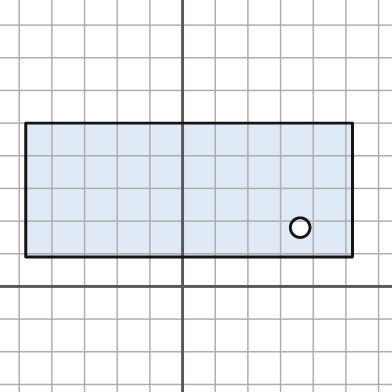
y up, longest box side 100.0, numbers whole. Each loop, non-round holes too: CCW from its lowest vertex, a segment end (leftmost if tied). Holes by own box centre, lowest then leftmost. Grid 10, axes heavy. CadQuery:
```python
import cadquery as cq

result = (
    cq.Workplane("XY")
    .moveTo(-48.0, 9.0)
    .lineTo(52.0, 9.0)
    .lineTo(52.0, 50.0)
    .lineTo(-48.0, 50.0)
    .close()
    .moveTo(36.0, 18.0)
    .circle(3.0)
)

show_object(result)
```